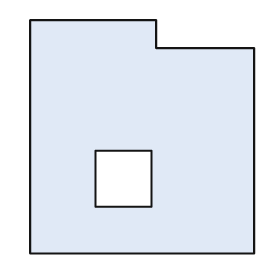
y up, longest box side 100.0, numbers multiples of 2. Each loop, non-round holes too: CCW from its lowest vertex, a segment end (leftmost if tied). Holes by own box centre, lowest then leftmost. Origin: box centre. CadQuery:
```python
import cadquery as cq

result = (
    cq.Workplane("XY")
    .moveTo(-48.0, -50.0)
    .lineTo(48.0, -50.0)
    .lineTo(48.0, 38.0)
    .lineTo(6.0, 38.0)
    .lineTo(6.0, 50.0)
    .lineTo(-48.0, 50.0)
    .close()
    .moveTo(-20.0, -30.0)
    .lineTo(4.0, -30.0)
    .lineTo(4.0, -6.0)
    .lineTo(-20.0, -6.0)
    .close()
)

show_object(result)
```